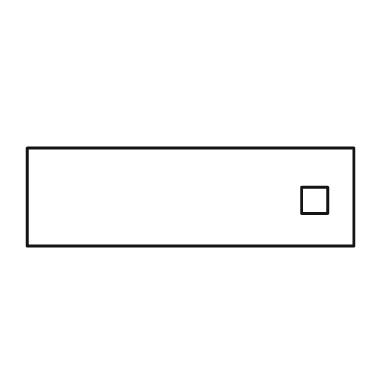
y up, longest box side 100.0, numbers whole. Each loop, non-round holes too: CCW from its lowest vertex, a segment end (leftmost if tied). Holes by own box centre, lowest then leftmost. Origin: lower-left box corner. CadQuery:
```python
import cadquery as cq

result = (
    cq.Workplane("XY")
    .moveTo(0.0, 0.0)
    .lineTo(100.0, 0.0)
    .lineTo(100.0, 30.0)
    .lineTo(0.0, 30.0)
    .close()
    .moveTo(84.0, 10.0)
    .lineTo(92.0, 10.0)
    .lineTo(92.0, 18.0)
    .lineTo(84.0, 18.0)
    .close()
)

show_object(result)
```